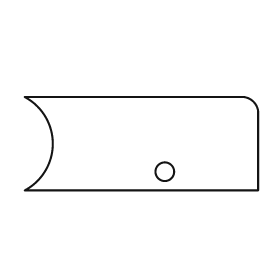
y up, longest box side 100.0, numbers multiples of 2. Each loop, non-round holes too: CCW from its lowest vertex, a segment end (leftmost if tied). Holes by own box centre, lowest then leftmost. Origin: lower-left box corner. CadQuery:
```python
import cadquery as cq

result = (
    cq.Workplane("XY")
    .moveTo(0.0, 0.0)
    .lineTo(100.0, 0.0)
    .lineTo(100.0, 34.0)
    .threePointArc((98.0, 38.0), (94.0, 40.0))
    .lineTo(0.0, 40.0)
    .threePointArc((12.0, 20.0), (0.0, 0.0))
    .close()
    .moveTo(60.0, 8.0)
    .circle(4.0)
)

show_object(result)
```